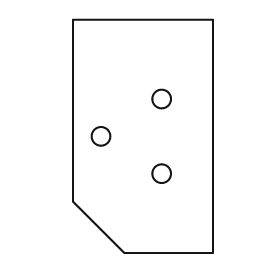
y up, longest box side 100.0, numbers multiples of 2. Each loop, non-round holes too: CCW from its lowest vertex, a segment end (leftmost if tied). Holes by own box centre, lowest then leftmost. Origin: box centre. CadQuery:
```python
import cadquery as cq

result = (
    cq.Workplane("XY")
    .moveTo(-8.0, -50.0)
    .lineTo(30.0, -50.0)
    .lineTo(30.0, 50.0)
    .lineTo(-30.0, 50.0)
    .lineTo(-30.0, -28.0)
    .close()
    .moveTo(8.0, -16.0)
    .circle(4.0)
    .moveTo(-18.0, 0.0)
    .circle(4.0)
    .moveTo(8.0, 16.0)
    .circle(4.0)
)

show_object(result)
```